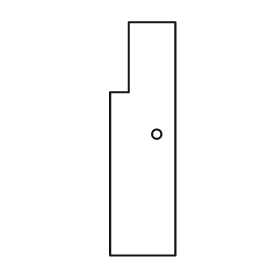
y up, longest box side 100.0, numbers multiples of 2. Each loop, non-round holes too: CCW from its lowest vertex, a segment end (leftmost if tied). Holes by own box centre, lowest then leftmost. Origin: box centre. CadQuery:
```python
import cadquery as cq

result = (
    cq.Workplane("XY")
    .moveTo(-14.0, -50.0)
    .lineTo(14.0, -50.0)
    .lineTo(14.0, 50.0)
    .lineTo(-6.0, 50.0)
    .lineTo(-6.0, 20.0)
    .lineTo(-14.0, 20.0)
    .close()
    .moveTo(6.0, 2.0)
    .circle(2.0)
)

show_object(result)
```